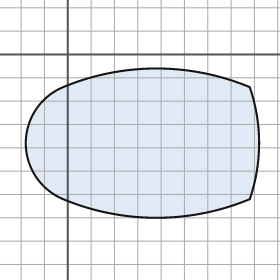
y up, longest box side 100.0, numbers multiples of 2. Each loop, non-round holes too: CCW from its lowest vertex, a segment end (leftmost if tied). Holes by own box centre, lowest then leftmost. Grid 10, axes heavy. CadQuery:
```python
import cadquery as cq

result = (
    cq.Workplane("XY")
    .moveTo(-2.0, -62.0)
    .threePointArc((38.0, -70.0), (78.0, -62.0))
    .threePointArc((82.0, -38.0), (78.0, -14.0))
    .threePointArc((38.0, -6.0), (-2.0, -14.0))
    .threePointArc((-18.0, -38.0), (-2.0, -62.0))
    .close()
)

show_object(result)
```